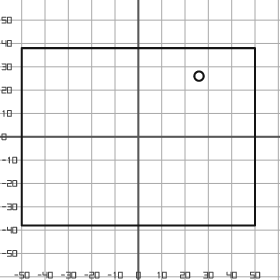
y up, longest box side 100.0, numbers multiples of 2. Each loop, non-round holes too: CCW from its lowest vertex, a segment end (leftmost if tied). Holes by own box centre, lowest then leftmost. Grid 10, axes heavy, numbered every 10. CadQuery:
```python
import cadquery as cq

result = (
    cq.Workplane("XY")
    .moveTo(-50.0, -38.0)
    .lineTo(50.0, -38.0)
    .lineTo(50.0, 38.0)
    .lineTo(-50.0, 38.0)
    .close()
    .moveTo(26.0, 26.0)
    .circle(2.0)
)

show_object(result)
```